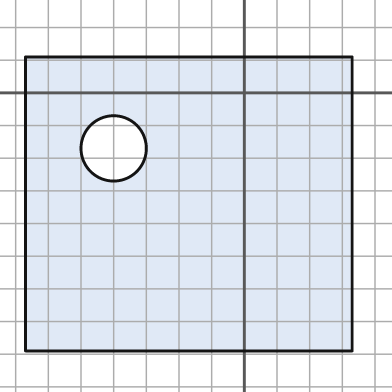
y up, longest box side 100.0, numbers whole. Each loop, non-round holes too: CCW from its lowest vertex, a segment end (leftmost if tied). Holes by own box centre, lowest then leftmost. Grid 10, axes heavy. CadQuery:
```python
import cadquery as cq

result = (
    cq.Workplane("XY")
    .moveTo(-67.0, -79.0)
    .lineTo(33.0, -79.0)
    .lineTo(33.0, 11.0)
    .lineTo(-67.0, 11.0)
    .close()
    .moveTo(-40.0, -17.0)
    .circle(10.0)
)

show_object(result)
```